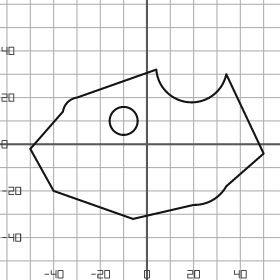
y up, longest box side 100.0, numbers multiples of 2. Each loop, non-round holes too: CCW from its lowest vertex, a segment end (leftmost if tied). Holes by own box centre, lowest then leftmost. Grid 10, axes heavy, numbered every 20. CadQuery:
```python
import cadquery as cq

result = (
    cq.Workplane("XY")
    .moveTo(-6.0, -32.0)
    .lineTo(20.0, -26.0)
    .threePointArc((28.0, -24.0), (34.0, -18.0))
    .lineTo(50.0, -4.0)
    .lineTo(34.0, 30.0)
    .threePointArc((18.0, 18.0), (4.0, 32.0))
    .lineTo(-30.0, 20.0)
    .threePointArc((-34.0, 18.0), (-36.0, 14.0))
    .lineTo(-50.0, -2.0)
    .lineTo(-40.0, -20.0)
    .close()
    .moveTo(-10.0, 10.0)
    .circle(6.0)
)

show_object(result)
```